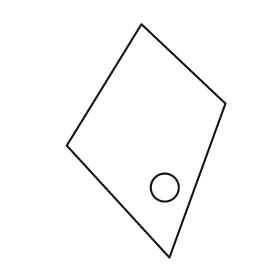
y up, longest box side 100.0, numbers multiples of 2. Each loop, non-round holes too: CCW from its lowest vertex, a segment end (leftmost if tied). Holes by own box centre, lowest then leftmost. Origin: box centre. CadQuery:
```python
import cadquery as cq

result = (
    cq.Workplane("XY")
    .moveTo(10.0, -50.0)
    .lineTo(34.0, 16.0)
    .lineTo(-2.0, 50.0)
    .lineTo(-34.0, -2.0)
    .close()
    .moveTo(8.0, -20.0)
    .circle(6.0)
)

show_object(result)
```